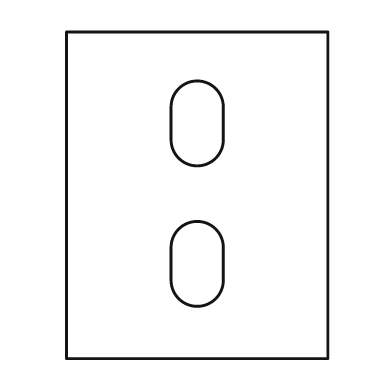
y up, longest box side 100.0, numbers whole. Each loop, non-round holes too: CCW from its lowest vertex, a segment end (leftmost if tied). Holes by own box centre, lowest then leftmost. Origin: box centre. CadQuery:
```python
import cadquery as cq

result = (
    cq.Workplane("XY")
    .moveTo(-40.0, -50.0)
    .lineTo(40.0, -50.0)
    .lineTo(40.0, 50.0)
    .lineTo(-40.0, 50.0)
    .close()
    .moveTo(-8.0, -26.0)
    .threePointArc((0.0, -34.0), (8.0, -26.0))
    .lineTo(8.0, -16.0)
    .threePointArc((0.0, -8.0), (-8.0, -16.0))
    .close()
    .moveTo(-8.0, 17.0)
    .threePointArc((0.0, 9.0), (8.0, 17.0))
    .lineTo(8.0, 27.0)
    .threePointArc((0.0, 35.0), (-8.0, 27.0))
    .close()
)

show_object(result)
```